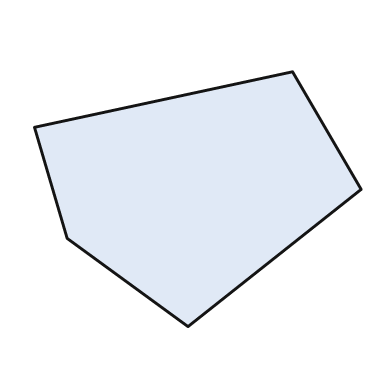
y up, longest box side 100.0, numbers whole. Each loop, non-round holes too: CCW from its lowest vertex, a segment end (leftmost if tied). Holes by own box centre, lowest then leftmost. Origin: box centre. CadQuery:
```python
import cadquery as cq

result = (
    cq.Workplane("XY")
    .moveTo(-3.0, -39.0)
    .lineTo(50.0, 3.0)
    .lineTo(29.0, 39.0)
    .lineTo(-50.0, 22.0)
    .lineTo(-40.0, -12.0)
    .close()
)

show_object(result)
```